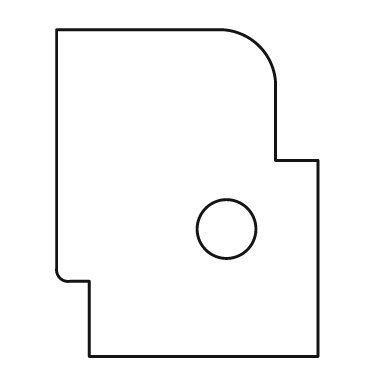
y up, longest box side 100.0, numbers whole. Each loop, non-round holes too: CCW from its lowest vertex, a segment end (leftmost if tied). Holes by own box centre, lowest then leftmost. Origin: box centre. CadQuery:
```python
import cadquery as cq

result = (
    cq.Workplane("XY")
    .moveTo(-30.0, -50.0)
    .lineTo(40.0, -50.0)
    .lineTo(40.0, 10.0)
    .lineTo(27.0, 10.0)
    .lineTo(27.0, 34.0)
    .threePointArc((22.0, 45.0), (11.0, 50.0))
    .lineTo(-40.0, 50.0)
    .lineTo(-40.0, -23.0)
    .threePointArc((-39.0, -26.0), (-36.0, -27.0))
    .lineTo(-30.0, -27.0)
    .close()
    .moveTo(12.0, -11.0)
    .circle(9.0)
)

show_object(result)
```